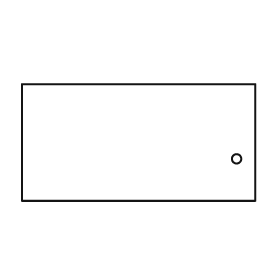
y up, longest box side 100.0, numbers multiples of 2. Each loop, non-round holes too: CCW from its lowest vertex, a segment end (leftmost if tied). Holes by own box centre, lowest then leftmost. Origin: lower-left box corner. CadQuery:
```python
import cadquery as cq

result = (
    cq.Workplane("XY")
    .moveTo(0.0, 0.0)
    .lineTo(100.0, 0.0)
    .lineTo(100.0, 50.0)
    .lineTo(0.0, 50.0)
    .close()
    .moveTo(92.0, 18.0)
    .circle(2.0)
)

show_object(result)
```